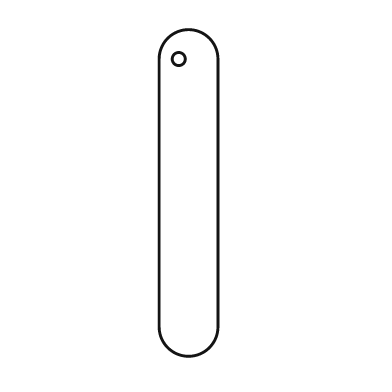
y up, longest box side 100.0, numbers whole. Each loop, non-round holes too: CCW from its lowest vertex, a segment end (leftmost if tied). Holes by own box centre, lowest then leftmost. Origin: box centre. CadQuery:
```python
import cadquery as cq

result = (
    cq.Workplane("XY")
    .moveTo(-9.0, -41.0)
    .threePointArc((0.0, -50.0), (9.0, -41.0))
    .lineTo(9.0, 41.0)
    .threePointArc((0.0, 50.0), (-9.0, 41.0))
    .close()
    .moveTo(-3.0, 41.0)
    .circle(2.0)
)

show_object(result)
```